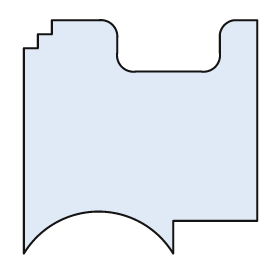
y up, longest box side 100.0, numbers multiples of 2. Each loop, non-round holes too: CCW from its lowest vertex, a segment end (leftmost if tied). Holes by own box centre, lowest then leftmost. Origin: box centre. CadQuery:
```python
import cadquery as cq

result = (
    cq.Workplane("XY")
    .moveTo(-50.0, -50.0)
    .threePointArc((-18.0, -32.0), (14.0, -50.0))
    .lineTo(14.0, -36.0)
    .lineTo(50.0, -36.0)
    .lineTo(50.0, 50.0)
    .lineTo(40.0, 50.0)
    .threePointArc((36.0, 48.0), (34.0, 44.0))
    .lineTo(34.0, 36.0)
    .threePointArc((32.0, 30.0), (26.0, 28.0))
    .lineTo(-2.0, 28.0)
    .threePointArc((-8.0, 30.0), (-10.0, 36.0))
    .lineTo(-10.0, 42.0)
    .threePointArc((-12.0, 48.0), (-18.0, 50.0))
    .lineTo(-38.0, 50.0)
    .lineTo(-38.0, 44.0)
    .lineTo(-44.0, 44.0)
    .lineTo(-44.0, 38.0)
    .lineTo(-50.0, 38.0)
    .close()
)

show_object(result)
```